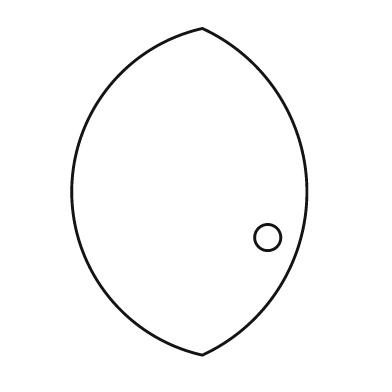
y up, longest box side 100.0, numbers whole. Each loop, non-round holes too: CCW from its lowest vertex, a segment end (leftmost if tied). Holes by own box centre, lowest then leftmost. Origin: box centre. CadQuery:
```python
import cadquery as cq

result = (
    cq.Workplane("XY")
    .moveTo(4.0, -50.0)
    .threePointArc((36.0, 0.0), (4.0, 50.0))
    .threePointArc((-36.0, 0.0), (4.0, -50.0))
    .close()
    .moveTo(24.0, -14.0)
    .circle(4.0)
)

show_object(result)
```